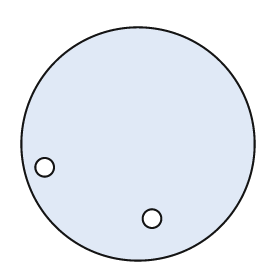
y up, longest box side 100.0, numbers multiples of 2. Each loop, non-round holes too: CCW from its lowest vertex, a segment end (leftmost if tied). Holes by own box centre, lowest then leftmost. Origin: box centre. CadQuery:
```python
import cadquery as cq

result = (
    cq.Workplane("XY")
    .moveTo(0.0, 0.0)
    .circle(50.0)
    .moveTo(6.0, -32.0)
    .circle(4.0)
    .moveTo(-40.0, -10.0)
    .circle(4.0)
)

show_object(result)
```